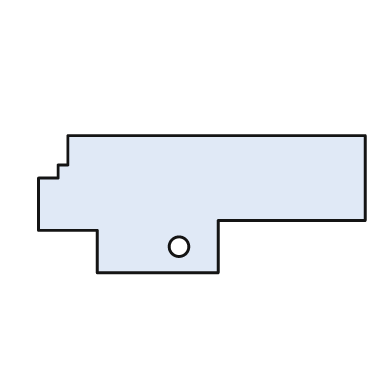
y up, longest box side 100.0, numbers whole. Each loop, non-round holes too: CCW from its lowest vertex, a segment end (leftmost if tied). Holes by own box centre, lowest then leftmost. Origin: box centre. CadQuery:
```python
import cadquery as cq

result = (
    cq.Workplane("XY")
    .moveTo(-32.0, -21.0)
    .lineTo(5.0, -21.0)
    .lineTo(5.0, -5.0)
    .lineTo(50.0, -5.0)
    .lineTo(50.0, 21.0)
    .lineTo(-41.0, 21.0)
    .lineTo(-41.0, 12.0)
    .lineTo(-44.0, 12.0)
    .lineTo(-44.0, 8.0)
    .lineTo(-50.0, 8.0)
    .lineTo(-50.0, -8.0)
    .lineTo(-32.0, -8.0)
    .close()
    .moveTo(-7.0, -13.0)
    .circle(3.0)
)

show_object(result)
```